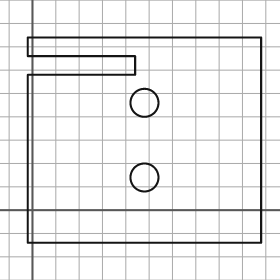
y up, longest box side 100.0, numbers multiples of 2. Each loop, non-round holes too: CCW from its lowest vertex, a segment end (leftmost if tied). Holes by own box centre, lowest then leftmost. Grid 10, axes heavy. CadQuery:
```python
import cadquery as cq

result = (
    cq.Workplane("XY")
    .moveTo(-2.0, -14.0)
    .lineTo(98.0, -14.0)
    .lineTo(98.0, 74.0)
    .lineTo(-2.0, 74.0)
    .lineTo(-2.0, 66.0)
    .lineTo(44.0, 66.0)
    .lineTo(44.0, 58.0)
    .lineTo(-2.0, 58.0)
    .close()
    .moveTo(48.0, 14.0)
    .circle(6.0)
    .moveTo(48.0, 46.0)
    .circle(6.0)
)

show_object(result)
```